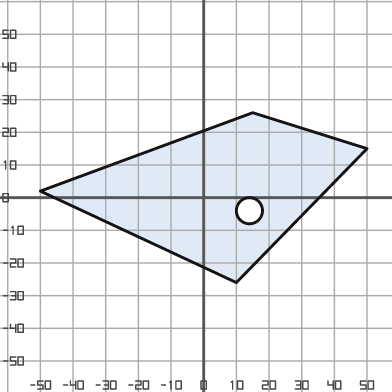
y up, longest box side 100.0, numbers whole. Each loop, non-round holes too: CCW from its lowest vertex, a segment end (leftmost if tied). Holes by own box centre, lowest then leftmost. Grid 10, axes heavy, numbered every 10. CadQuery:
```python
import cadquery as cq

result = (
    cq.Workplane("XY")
    .moveTo(10.0, -26.0)
    .lineTo(50.0, 15.0)
    .lineTo(15.0, 26.0)
    .lineTo(-50.0, 2.0)
    .close()
    .moveTo(14.0, -4.0)
    .circle(4.0)
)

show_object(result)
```